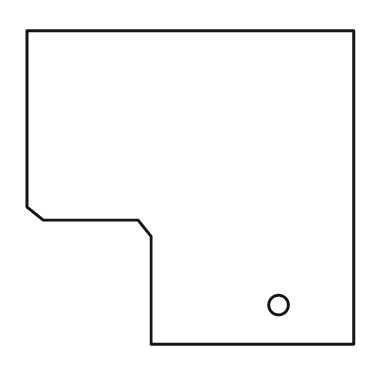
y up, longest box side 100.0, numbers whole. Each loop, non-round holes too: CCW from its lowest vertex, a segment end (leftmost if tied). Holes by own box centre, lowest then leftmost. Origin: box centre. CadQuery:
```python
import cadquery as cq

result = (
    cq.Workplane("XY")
    .moveTo(-12.0, -48.0)
    .lineTo(50.0, -48.0)
    .lineTo(50.0, 48.0)
    .lineTo(-50.0, 48.0)
    .lineTo(-50.0, -6.0)
    .lineTo(-45.0, -10.0)
    .lineTo(-16.0, -10.0)
    .lineTo(-12.0, -15.0)
    .close()
    .moveTo(27.0, -36.0)
    .circle(3.0)
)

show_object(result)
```